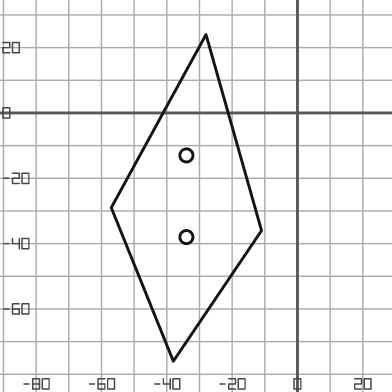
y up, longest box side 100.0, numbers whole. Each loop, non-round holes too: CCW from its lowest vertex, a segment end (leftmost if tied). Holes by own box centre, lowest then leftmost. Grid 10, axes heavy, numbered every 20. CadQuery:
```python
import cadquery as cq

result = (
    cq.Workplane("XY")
    .moveTo(-38.0, -76.0)
    .lineTo(-11.0, -36.0)
    .lineTo(-28.0, 24.0)
    .lineTo(-57.0, -29.0)
    .close()
    .moveTo(-34.0, -38.0)
    .circle(2.0)
    .moveTo(-34.0, -13.0)
    .circle(2.0)
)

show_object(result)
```